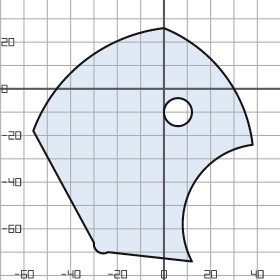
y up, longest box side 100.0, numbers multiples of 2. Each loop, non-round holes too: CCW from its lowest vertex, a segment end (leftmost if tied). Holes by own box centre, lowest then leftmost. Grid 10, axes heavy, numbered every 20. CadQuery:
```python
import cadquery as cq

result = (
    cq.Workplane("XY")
    .moveTo(12.0, -74.0)
    .threePointArc((12.0, -42.0), (38.0, -24.0))
    .threePointArc((26.0, 6.0), (0.0, 26.0))
    .threePointArc((-34.0, 12.0), (-56.0, -18.0))
    .lineTo(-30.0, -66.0)
    .threePointArc((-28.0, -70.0), (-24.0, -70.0))
    .close()
    .moveTo(6.0, -10.0)
    .circle(6.0)
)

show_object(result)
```